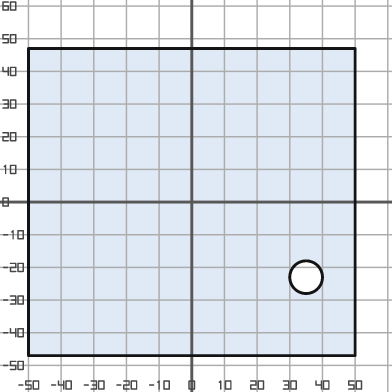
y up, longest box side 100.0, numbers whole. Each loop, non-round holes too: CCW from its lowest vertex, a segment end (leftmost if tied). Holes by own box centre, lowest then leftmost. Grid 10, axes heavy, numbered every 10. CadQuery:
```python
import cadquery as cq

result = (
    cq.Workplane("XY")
    .moveTo(-50.0, -47.0)
    .lineTo(50.0, -47.0)
    .lineTo(50.0, 47.0)
    .lineTo(-50.0, 47.0)
    .close()
    .moveTo(35.0, -23.0)
    .circle(5.0)
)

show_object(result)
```